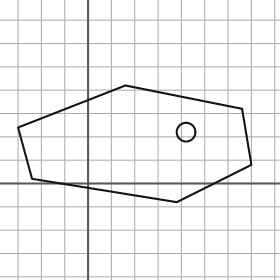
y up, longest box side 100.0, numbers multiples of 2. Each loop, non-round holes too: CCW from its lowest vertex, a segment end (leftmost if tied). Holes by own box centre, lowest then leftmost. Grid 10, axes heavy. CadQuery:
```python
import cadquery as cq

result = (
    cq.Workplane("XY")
    .moveTo(38.0, -8.0)
    .lineTo(70.0, 8.0)
    .lineTo(66.0, 32.0)
    .lineTo(16.0, 42.0)
    .lineTo(-30.0, 24.0)
    .lineTo(-24.0, 2.0)
    .close()
    .moveTo(42.0, 22.0)
    .circle(4.0)
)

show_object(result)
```